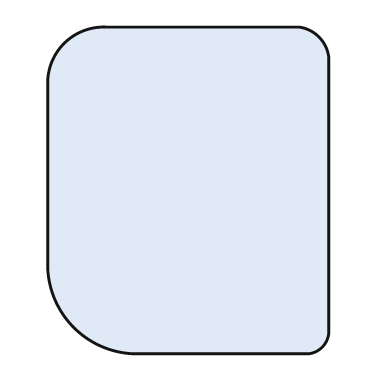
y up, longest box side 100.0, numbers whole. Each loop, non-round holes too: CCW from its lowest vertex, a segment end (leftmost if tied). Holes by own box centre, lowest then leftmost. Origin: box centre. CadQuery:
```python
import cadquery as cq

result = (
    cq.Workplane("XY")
    .moveTo(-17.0, -50.0)
    .lineTo(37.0, -50.0)
    .threePointArc((41.0, -48.0), (43.0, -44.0))
    .lineTo(43.0, 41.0)
    .threePointArc((40.0, 47.0), (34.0, 50.0))
    .lineTo(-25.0, 50.0)
    .threePointArc((-38.0, 45.0), (-43.0, 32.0))
    .lineTo(-43.0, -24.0)
    .threePointArc((-35.0, -42.0), (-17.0, -50.0))
    .close()
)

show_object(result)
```